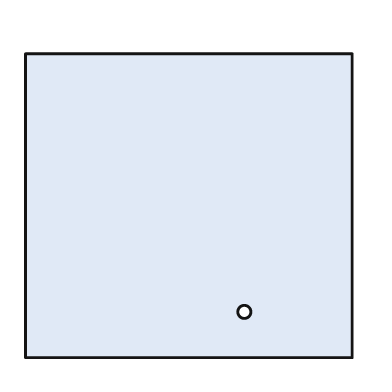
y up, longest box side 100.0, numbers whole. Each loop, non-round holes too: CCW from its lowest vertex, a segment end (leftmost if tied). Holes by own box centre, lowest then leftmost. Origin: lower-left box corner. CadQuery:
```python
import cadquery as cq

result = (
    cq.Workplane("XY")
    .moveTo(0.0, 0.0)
    .lineTo(100.0, 0.0)
    .lineTo(100.0, 93.0)
    .lineTo(0.0, 93.0)
    .close()
    .moveTo(67.0, 14.0)
    .circle(2.0)
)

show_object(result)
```